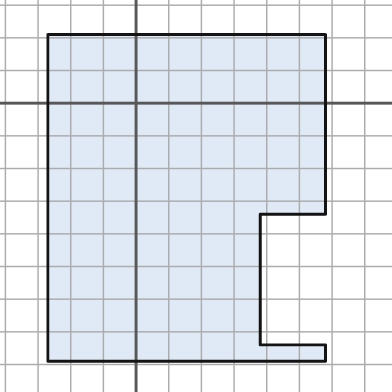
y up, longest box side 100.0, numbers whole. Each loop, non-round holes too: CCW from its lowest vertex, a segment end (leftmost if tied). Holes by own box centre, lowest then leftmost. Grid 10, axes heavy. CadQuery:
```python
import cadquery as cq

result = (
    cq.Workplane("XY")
    .moveTo(-27.0, -79.0)
    .lineTo(58.0, -79.0)
    .lineTo(58.0, -74.0)
    .lineTo(38.0, -74.0)
    .lineTo(38.0, -34.0)
    .lineTo(58.0, -34.0)
    .lineTo(58.0, 21.0)
    .lineTo(-27.0, 21.0)
    .close()
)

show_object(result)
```